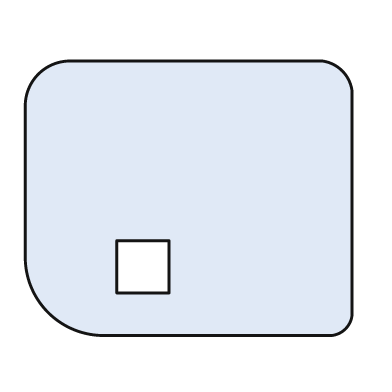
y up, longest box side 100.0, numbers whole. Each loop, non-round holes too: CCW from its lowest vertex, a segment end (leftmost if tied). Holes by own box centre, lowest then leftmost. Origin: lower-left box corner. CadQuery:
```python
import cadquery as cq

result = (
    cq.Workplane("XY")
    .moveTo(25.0, 0.0)
    .lineTo(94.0, 0.0)
    .threePointArc((98.0, 2.0), (100.0, 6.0))
    .lineTo(100.0, 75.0)
    .threePointArc((97.0, 81.0), (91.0, 84.0))
    .lineTo(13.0, 84.0)
    .threePointArc((4.0, 80.0), (0.0, 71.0))
    .lineTo(0.0, 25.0)
    .threePointArc((7.0, 7.0), (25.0, 0.0))
    .close()
    .moveTo(28.0, 13.0)
    .lineTo(44.0, 13.0)
    .lineTo(44.0, 29.0)
    .lineTo(28.0, 29.0)
    .close()
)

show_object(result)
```